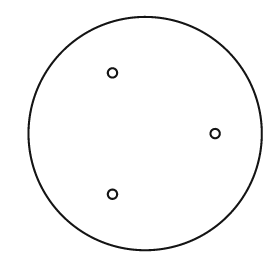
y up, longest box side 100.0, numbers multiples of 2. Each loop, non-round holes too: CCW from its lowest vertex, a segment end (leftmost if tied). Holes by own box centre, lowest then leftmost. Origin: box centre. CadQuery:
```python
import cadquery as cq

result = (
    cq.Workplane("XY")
    .moveTo(0.0, 0.0)
    .circle(50.0)
    .moveTo(-14.0, -26.0)
    .circle(2.0)
    .moveTo(30.0, 0.0)
    .circle(2.0)
    .moveTo(-14.0, 26.0)
    .circle(2.0)
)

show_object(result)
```